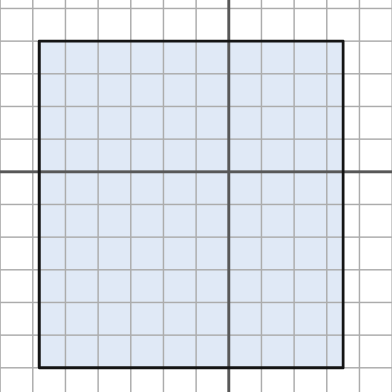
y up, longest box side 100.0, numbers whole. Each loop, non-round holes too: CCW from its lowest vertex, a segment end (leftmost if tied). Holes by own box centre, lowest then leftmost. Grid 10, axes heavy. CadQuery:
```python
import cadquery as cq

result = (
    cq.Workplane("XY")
    .moveTo(-58.0, -60.0)
    .lineTo(35.0, -60.0)
    .lineTo(35.0, 40.0)
    .lineTo(-58.0, 40.0)
    .close()
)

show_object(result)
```